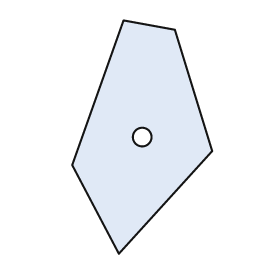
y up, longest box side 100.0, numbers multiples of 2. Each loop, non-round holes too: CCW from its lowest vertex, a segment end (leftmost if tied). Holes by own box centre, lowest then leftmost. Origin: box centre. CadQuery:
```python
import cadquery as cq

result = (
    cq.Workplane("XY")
    .moveTo(-10.0, -50.0)
    .lineTo(30.0, -6.0)
    .lineTo(14.0, 46.0)
    .lineTo(-8.0, 50.0)
    .lineTo(-30.0, -12.0)
    .close()
    .moveTo(0.0, 0.0)
    .circle(4.0)
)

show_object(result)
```